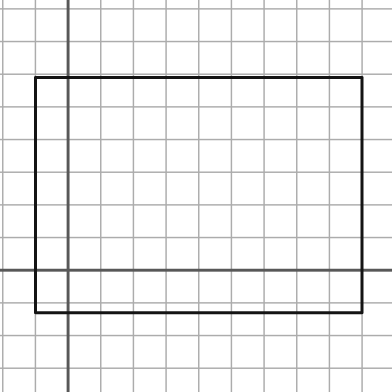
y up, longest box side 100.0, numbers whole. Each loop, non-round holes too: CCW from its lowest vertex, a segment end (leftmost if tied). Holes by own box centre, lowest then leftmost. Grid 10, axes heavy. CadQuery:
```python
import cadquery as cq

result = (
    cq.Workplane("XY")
    .moveTo(-10.0, -13.0)
    .lineTo(90.0, -13.0)
    .lineTo(90.0, 59.0)
    .lineTo(-10.0, 59.0)
    .close()
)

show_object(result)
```